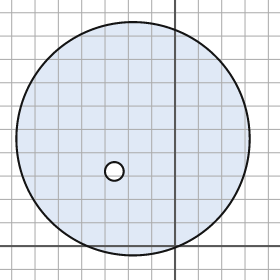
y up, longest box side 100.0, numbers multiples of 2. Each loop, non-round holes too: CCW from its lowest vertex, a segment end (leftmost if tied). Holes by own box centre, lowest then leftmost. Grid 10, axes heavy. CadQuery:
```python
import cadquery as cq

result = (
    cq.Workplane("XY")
    .moveTo(-18.0, 46.0)
    .circle(50.0)
    .moveTo(-26.0, 32.0)
    .circle(4.0)
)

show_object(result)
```